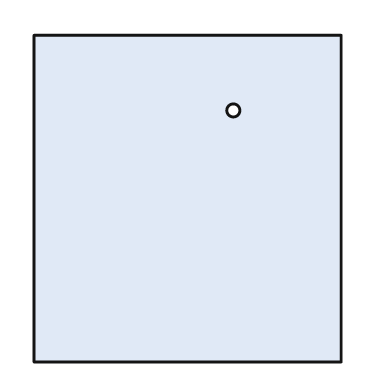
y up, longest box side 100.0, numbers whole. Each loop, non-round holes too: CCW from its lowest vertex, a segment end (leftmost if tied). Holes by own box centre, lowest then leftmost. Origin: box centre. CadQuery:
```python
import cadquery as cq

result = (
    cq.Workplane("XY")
    .moveTo(-47.0, -50.0)
    .lineTo(47.0, -50.0)
    .lineTo(47.0, 50.0)
    .lineTo(-47.0, 50.0)
    .close()
    .moveTo(14.0, 27.0)
    .circle(2.0)
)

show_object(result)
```